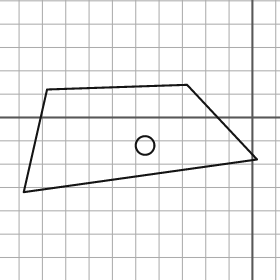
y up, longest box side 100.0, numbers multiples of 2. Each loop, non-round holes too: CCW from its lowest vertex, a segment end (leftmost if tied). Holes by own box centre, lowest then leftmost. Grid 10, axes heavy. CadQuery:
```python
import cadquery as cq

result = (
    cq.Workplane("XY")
    .moveTo(-98.0, -32.0)
    .lineTo(2.0, -18.0)
    .lineTo(-28.0, 14.0)
    .lineTo(-88.0, 12.0)
    .close()
    .moveTo(-46.0, -12.0)
    .circle(4.0)
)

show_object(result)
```